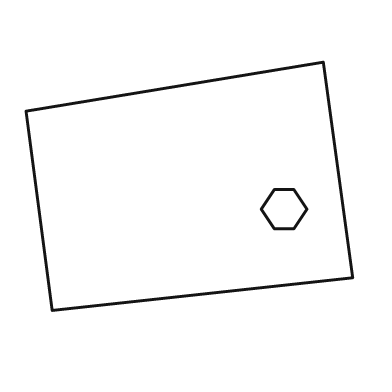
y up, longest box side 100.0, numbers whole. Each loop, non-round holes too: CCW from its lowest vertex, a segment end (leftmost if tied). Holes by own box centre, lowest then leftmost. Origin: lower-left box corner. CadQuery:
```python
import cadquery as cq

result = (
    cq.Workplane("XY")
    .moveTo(8.0, 0.0)
    .lineTo(100.0, 10.0)
    .lineTo(91.0, 76.0)
    .lineTo(0.0, 61.0)
    .close()
    .moveTo(76.0, 25.0)
    .lineTo(82.0, 25.0)
    .lineTo(86.0, 31.0)
    .lineTo(82.0, 37.0)
    .lineTo(76.0, 37.0)
    .lineTo(72.0, 31.0)
    .close()
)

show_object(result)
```